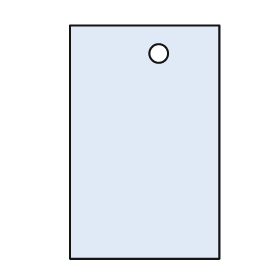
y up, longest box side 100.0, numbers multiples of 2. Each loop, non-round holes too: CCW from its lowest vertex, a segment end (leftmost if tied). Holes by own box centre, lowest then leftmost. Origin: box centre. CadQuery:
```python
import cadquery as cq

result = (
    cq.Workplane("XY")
    .moveTo(-32.0, -50.0)
    .lineTo(32.0, -50.0)
    .lineTo(32.0, 50.0)
    .lineTo(-32.0, 50.0)
    .close()
    .moveTo(6.0, 38.0)
    .circle(4.0)
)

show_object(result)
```